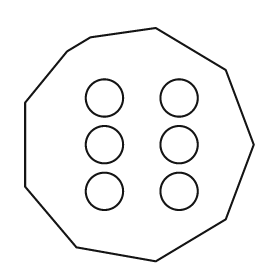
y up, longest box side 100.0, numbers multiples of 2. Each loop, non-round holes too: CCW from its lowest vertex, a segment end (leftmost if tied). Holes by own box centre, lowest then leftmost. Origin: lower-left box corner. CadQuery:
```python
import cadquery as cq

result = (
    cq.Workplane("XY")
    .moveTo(56.0, 0.0)
    .lineTo(86.0, 18.0)
    .lineTo(98.0, 50.0)
    .lineTo(86.0, 82.0)
    .lineTo(56.0, 100.0)
    .lineTo(28.0, 96.0)
    .lineTo(18.0, 90.0)
    .lineTo(0.0, 68.0)
    .lineTo(0.0, 32.0)
    .lineTo(22.0, 6.0)
    .close()
    .moveTo(34.0, 30.0)
    .circle(8.0)
    .moveTo(66.0, 30.0)
    .circle(8.0)
    .moveTo(34.0, 50.0)
    .circle(8.0)
    .moveTo(66.0, 50.0)
    .circle(8.0)
    .moveTo(34.0, 70.0)
    .circle(8.0)
    .moveTo(66.0, 70.0)
    .circle(8.0)
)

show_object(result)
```